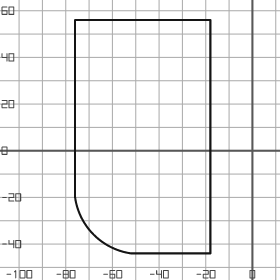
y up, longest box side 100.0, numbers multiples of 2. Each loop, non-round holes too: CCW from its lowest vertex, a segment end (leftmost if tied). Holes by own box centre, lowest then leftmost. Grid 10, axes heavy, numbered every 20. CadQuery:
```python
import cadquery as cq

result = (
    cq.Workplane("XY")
    .moveTo(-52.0, -44.0)
    .lineTo(-18.0, -44.0)
    .lineTo(-18.0, 56.0)
    .lineTo(-76.0, 56.0)
    .lineTo(-76.0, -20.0)
    .threePointArc((-68.0, -36.0), (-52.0, -44.0))
    .close()
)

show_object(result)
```